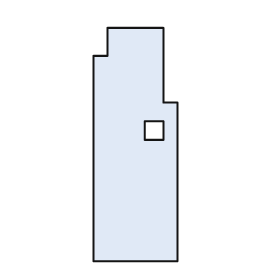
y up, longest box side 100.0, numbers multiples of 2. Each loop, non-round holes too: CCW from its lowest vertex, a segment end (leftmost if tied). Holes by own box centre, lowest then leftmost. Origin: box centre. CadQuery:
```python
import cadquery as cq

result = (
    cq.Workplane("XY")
    .moveTo(-18.0, -50.0)
    .lineTo(18.0, -50.0)
    .lineTo(18.0, 18.0)
    .lineTo(12.0, 18.0)
    .lineTo(12.0, 50.0)
    .lineTo(-12.0, 50.0)
    .lineTo(-12.0, 38.0)
    .lineTo(-18.0, 38.0)
    .close()
    .moveTo(4.0, 2.0)
    .lineTo(12.0, 2.0)
    .lineTo(12.0, 10.0)
    .lineTo(4.0, 10.0)
    .close()
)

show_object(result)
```